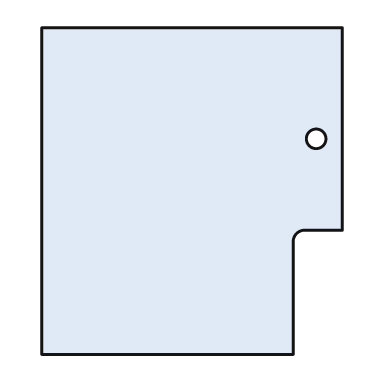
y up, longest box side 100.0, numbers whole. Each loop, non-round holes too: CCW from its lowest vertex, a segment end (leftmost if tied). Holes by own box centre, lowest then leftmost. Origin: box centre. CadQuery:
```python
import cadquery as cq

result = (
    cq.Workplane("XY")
    .moveTo(-46.0, -50.0)
    .lineTo(31.0, -50.0)
    .lineTo(31.0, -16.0)
    .threePointArc((32.0, -13.0), (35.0, -12.0))
    .lineTo(46.0, -12.0)
    .lineTo(46.0, 50.0)
    .lineTo(-46.0, 50.0)
    .close()
    .moveTo(38.0, 16.0)
    .circle(3.0)
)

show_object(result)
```